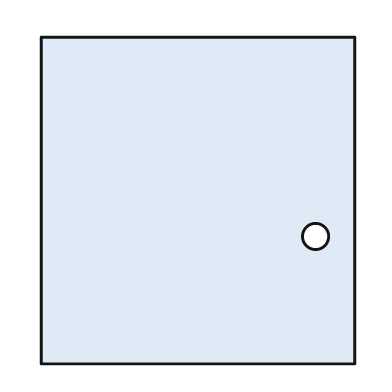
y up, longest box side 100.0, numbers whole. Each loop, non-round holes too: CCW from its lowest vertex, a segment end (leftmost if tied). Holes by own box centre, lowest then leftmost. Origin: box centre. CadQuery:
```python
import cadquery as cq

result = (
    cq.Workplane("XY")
    .moveTo(-48.0, -50.0)
    .lineTo(48.0, -50.0)
    .lineTo(48.0, 50.0)
    .lineTo(-48.0, 50.0)
    .close()
    .moveTo(36.0, -11.0)
    .circle(4.0)
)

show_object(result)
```